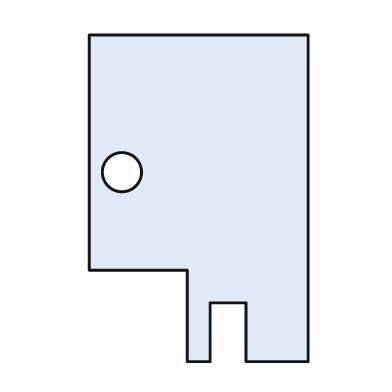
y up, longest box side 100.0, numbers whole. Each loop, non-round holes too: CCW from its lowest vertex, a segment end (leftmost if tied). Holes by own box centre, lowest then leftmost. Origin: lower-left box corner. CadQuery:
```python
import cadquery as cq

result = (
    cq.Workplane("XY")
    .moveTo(30.0, 0.0)
    .lineTo(37.0, 0.0)
    .lineTo(37.0, 18.0)
    .lineTo(48.0, 18.0)
    .lineTo(48.0, 0.0)
    .lineTo(67.0, 0.0)
    .lineTo(67.0, 100.0)
    .lineTo(0.0, 100.0)
    .lineTo(0.0, 28.0)
    .lineTo(30.0, 28.0)
    .close()
    .moveTo(10.0, 58.0)
    .circle(6.0)
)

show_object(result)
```